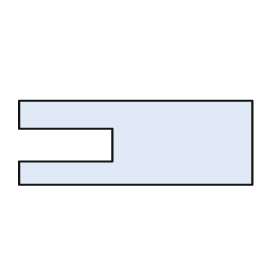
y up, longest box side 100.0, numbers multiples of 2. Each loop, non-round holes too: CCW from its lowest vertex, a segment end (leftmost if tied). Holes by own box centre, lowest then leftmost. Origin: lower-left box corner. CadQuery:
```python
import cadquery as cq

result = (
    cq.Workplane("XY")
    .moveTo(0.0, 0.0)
    .lineTo(100.0, 0.0)
    .lineTo(100.0, 36.0)
    .lineTo(0.0, 36.0)
    .lineTo(0.0, 24.0)
    .lineTo(40.0, 24.0)
    .lineTo(40.0, 10.0)
    .lineTo(0.0, 10.0)
    .close()
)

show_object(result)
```